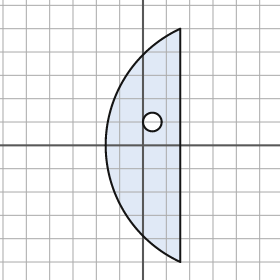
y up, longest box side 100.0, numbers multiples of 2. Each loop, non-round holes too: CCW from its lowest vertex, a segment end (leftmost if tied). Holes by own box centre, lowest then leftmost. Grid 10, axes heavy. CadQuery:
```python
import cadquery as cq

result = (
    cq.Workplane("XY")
    .moveTo(16.0, -50.0)
    .lineTo(16.0, 50.0)
    .threePointArc((-16.0, 0.0), (16.0, -50.0))
    .close()
    .moveTo(4.0, 10.0)
    .circle(4.0)
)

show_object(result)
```